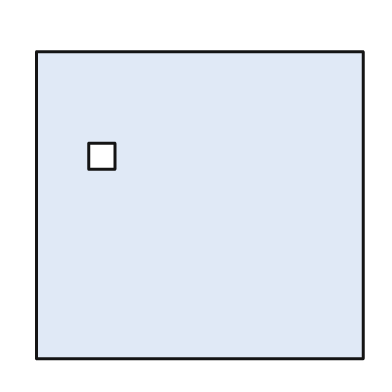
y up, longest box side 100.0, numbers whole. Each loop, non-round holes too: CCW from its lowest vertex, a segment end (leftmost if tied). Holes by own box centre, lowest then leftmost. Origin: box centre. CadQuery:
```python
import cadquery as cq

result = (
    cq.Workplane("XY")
    .moveTo(-50.0, -47.0)
    .lineTo(50.0, -47.0)
    .lineTo(50.0, 47.0)
    .lineTo(-50.0, 47.0)
    .close()
    .moveTo(-34.0, 11.0)
    .lineTo(-26.0, 11.0)
    .lineTo(-26.0, 19.0)
    .lineTo(-34.0, 19.0)
    .close()
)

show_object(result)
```